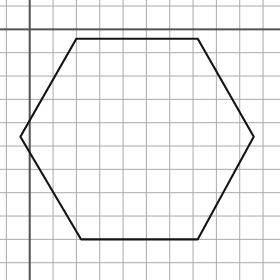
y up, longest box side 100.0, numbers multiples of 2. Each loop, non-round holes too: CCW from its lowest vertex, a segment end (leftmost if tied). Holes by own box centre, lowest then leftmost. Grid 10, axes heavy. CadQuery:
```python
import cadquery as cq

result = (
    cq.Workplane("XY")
    .moveTo(22.0, -90.0)
    .lineTo(72.0, -90.0)
    .lineTo(96.0, -46.0)
    .lineTo(72.0, -4.0)
    .lineTo(20.0, -4.0)
    .lineTo(-4.0, -46.0)
    .close()
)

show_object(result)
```